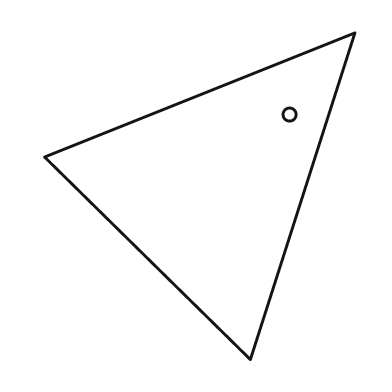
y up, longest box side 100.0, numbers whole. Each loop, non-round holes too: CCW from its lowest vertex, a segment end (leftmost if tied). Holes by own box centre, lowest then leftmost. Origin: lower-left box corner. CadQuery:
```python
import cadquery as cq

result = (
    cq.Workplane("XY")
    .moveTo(63.0, 0.0)
    .lineTo(95.0, 100.0)
    .lineTo(0.0, 62.0)
    .close()
    .moveTo(75.0, 75.0)
    .circle(2.0)
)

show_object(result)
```